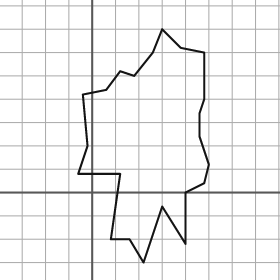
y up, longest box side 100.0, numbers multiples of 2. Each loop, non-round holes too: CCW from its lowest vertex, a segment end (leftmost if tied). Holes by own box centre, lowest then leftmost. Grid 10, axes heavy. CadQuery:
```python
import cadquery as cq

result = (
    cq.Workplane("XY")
    .moveTo(22.0, -30.0)
    .lineTo(30.0, -6.0)
    .lineTo(40.0, -22.0)
    .lineTo(40.0, 0.0)
    .lineTo(48.0, 4.0)
    .lineTo(50.0, 12.0)
    .lineTo(46.0, 24.0)
    .lineTo(46.0, 34.0)
    .lineTo(48.0, 40.0)
    .lineTo(48.0, 60.0)
    .lineTo(38.0, 62.0)
    .lineTo(30.0, 70.0)
    .lineTo(26.0, 60.0)
    .lineTo(18.0, 50.0)
    .lineTo(12.0, 52.0)
    .lineTo(6.0, 44.0)
    .lineTo(-4.0, 42.0)
    .lineTo(-2.0, 20.0)
    .lineTo(-6.0, 8.0)
    .lineTo(12.0, 8.0)
    .lineTo(8.0, -20.0)
    .lineTo(16.0, -20.0)
    .close()
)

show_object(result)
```